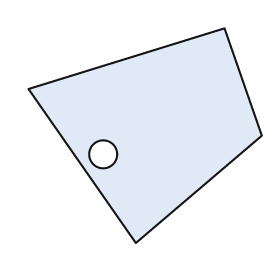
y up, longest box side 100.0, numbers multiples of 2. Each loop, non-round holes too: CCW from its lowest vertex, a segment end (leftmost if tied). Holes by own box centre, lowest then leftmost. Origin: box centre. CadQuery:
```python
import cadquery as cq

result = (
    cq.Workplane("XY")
    .moveTo(-4.0, -46.0)
    .lineTo(50.0, 0.0)
    .lineTo(34.0, 46.0)
    .lineTo(-50.0, 20.0)
    .close()
    .moveTo(-18.0, -8.0)
    .circle(6.0)
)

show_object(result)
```